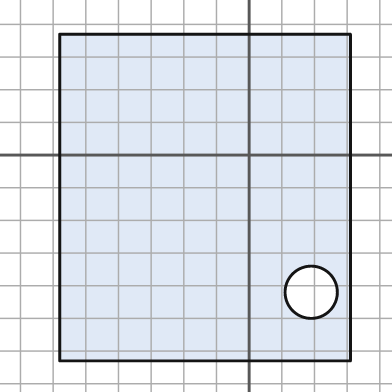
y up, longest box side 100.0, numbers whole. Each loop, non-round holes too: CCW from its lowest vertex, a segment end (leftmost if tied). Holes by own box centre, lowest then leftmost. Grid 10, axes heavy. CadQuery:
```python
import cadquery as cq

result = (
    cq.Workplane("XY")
    .moveTo(-58.0, -63.0)
    .lineTo(31.0, -63.0)
    .lineTo(31.0, 37.0)
    .lineTo(-58.0, 37.0)
    .close()
    .moveTo(19.0, -42.0)
    .circle(8.0)
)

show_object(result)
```